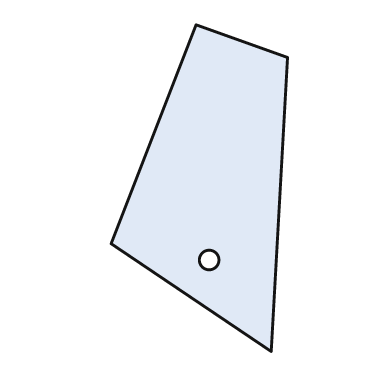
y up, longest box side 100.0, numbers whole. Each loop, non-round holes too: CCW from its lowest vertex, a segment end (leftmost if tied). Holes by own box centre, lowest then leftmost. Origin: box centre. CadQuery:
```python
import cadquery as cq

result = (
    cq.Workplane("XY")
    .moveTo(22.0, -50.0)
    .lineTo(27.0, 40.0)
    .lineTo(-1.0, 50.0)
    .lineTo(-27.0, -17.0)
    .close()
    .moveTo(3.0, -22.0)
    .circle(3.0)
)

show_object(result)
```